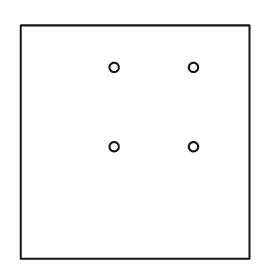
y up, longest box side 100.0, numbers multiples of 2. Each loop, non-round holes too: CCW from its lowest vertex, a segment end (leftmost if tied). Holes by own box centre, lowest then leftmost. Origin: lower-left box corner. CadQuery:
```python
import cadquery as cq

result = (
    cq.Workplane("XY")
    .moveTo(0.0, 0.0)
    .lineTo(98.0, 0.0)
    .lineTo(98.0, 100.0)
    .lineTo(0.0, 100.0)
    .close()
    .moveTo(40.0, 48.0)
    .circle(2.0)
    .moveTo(74.0, 48.0)
    .circle(2.0)
    .moveTo(40.0, 82.0)
    .circle(2.0)
    .moveTo(74.0, 82.0)
    .circle(2.0)
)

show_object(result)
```